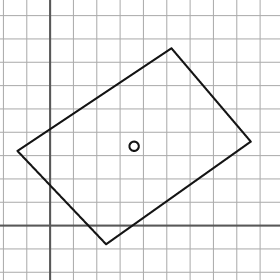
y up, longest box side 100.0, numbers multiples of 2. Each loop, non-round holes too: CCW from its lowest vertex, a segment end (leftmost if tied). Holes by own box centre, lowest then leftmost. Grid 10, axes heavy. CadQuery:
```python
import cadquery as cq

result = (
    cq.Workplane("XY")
    .moveTo(24.0, -8.0)
    .lineTo(86.0, 36.0)
    .lineTo(52.0, 76.0)
    .lineTo(-14.0, 32.0)
    .close()
    .moveTo(36.0, 34.0)
    .circle(2.0)
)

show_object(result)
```